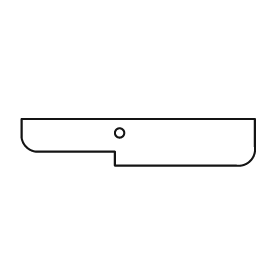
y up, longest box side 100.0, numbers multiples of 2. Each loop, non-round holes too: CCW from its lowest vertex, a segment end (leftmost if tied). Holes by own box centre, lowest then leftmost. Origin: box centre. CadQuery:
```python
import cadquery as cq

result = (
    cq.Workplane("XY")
    .moveTo(-10.0, -10.0)
    .lineTo(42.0, -10.0)
    .threePointArc((48.0, -8.0), (50.0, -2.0))
    .lineTo(50.0, 10.0)
    .lineTo(-50.0, 10.0)
    .lineTo(-50.0, 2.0)
    .threePointArc((-48.0, -2.0), (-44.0, -4.0))
    .lineTo(-10.0, -4.0)
    .close()
    .moveTo(-8.0, 4.0)
    .circle(2.0)
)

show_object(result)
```